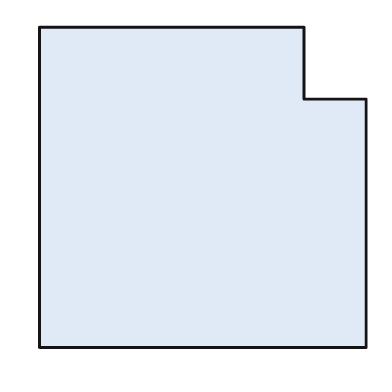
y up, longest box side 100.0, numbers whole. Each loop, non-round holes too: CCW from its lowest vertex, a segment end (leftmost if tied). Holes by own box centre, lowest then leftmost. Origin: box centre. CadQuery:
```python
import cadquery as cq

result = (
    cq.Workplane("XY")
    .moveTo(-50.0, -49.0)
    .lineTo(50.0, -49.0)
    .lineTo(50.0, 27.0)
    .lineTo(31.0, 27.0)
    .lineTo(31.0, 49.0)
    .lineTo(-50.0, 49.0)
    .close()
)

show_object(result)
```